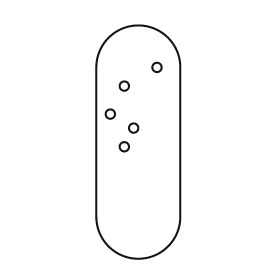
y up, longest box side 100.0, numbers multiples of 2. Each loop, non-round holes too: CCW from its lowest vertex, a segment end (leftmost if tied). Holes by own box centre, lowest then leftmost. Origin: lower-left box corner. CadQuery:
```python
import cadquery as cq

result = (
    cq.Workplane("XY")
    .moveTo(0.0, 18.0)
    .threePointArc((18.0, 0.0), (36.0, 18.0))
    .lineTo(36.0, 82.0)
    .threePointArc((18.0, 100.0), (0.0, 82.0))
    .close()
    .moveTo(12.0, 48.0)
    .circle(2.0)
    .moveTo(16.0, 56.0)
    .circle(2.0)
    .moveTo(6.0, 62.0)
    .circle(2.0)
    .moveTo(12.0, 74.0)
    .circle(2.0)
    .moveTo(26.0, 82.0)
    .circle(2.0)
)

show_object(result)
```